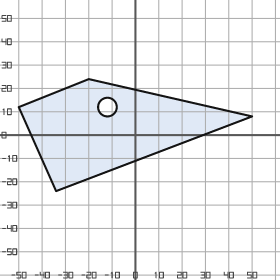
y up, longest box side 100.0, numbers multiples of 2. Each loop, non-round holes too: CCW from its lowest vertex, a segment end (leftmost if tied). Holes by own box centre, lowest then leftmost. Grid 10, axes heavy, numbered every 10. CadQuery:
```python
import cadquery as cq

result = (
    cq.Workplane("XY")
    .moveTo(-34.0, -24.0)
    .lineTo(50.0, 8.0)
    .lineTo(-20.0, 24.0)
    .lineTo(-50.0, 12.0)
    .close()
    .moveTo(-12.0, 12.0)
    .circle(4.0)
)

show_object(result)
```